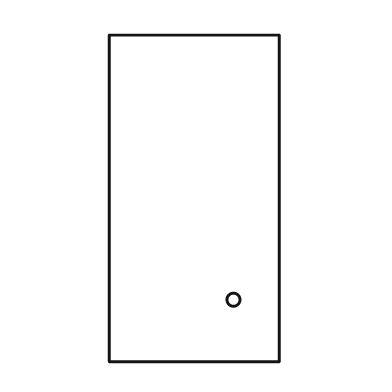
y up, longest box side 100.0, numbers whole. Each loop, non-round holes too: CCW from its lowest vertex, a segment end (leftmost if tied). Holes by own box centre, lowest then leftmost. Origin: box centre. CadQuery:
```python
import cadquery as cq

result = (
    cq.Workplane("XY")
    .moveTo(-26.0, -50.0)
    .lineTo(26.0, -50.0)
    .lineTo(26.0, 50.0)
    .lineTo(-26.0, 50.0)
    .close()
    .moveTo(12.0, -31.0)
    .circle(2.0)
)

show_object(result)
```